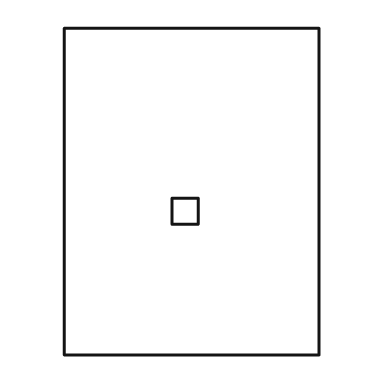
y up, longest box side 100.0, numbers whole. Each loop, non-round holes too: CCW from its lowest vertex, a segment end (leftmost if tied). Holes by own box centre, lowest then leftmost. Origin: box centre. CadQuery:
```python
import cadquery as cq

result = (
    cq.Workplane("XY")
    .moveTo(-39.0, -50.0)
    .lineTo(39.0, -50.0)
    .lineTo(39.0, 50.0)
    .lineTo(-39.0, 50.0)
    .close()
    .moveTo(-6.0, -10.0)
    .lineTo(2.0, -10.0)
    .lineTo(2.0, -2.0)
    .lineTo(-6.0, -2.0)
    .close()
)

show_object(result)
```